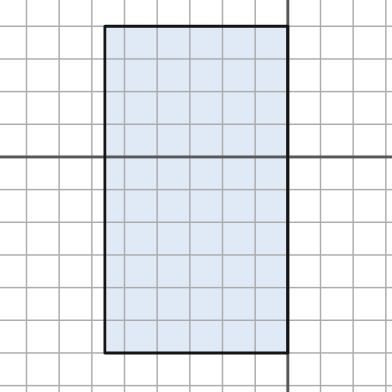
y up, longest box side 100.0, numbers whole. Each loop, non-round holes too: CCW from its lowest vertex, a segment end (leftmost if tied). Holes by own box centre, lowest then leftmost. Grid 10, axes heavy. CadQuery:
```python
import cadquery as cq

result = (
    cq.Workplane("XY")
    .moveTo(-56.0, -60.0)
    .lineTo(0.0, -60.0)
    .lineTo(0.0, 40.0)
    .lineTo(-56.0, 40.0)
    .close()
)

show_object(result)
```